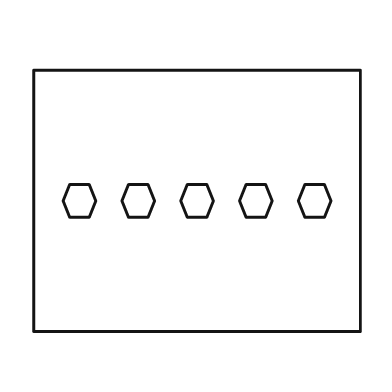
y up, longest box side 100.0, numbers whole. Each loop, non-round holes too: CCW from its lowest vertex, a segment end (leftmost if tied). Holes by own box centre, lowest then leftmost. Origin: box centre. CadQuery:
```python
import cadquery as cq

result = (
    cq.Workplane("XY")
    .moveTo(-50.0, -40.0)
    .lineTo(50.0, -40.0)
    .lineTo(50.0, 40.0)
    .lineTo(-50.0, 40.0)
    .close()
    .moveTo(-39.0, -5.0)
    .lineTo(-33.0, -5.0)
    .lineTo(-31.0, 0.0)
    .lineTo(-33.0, 5.0)
    .lineTo(-39.0, 5.0)
    .lineTo(-41.0, 0.0)
    .close()
    .moveTo(-21.0, -5.0)
    .lineTo(-15.0, -5.0)
    .lineTo(-13.0, 0.0)
    .lineTo(-15.0, 5.0)
    .lineTo(-21.0, 5.0)
    .lineTo(-23.0, 0.0)
    .close()
    .moveTo(-3.0, -5.0)
    .lineTo(3.0, -5.0)
    .lineTo(5.0, 0.0)
    .lineTo(3.0, 5.0)
    .lineTo(-3.0, 5.0)
    .lineTo(-5.0, 0.0)
    .close()
    .moveTo(15.0, -5.0)
    .lineTo(21.0, -5.0)
    .lineTo(23.0, 0.0)
    .lineTo(21.0, 5.0)
    .lineTo(15.0, 5.0)
    .lineTo(13.0, 0.0)
    .close()
    .moveTo(33.0, -5.0)
    .lineTo(39.0, -5.0)
    .lineTo(41.0, 0.0)
    .lineTo(39.0, 5.0)
    .lineTo(33.0, 5.0)
    .lineTo(31.0, 0.0)
    .close()
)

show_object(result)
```